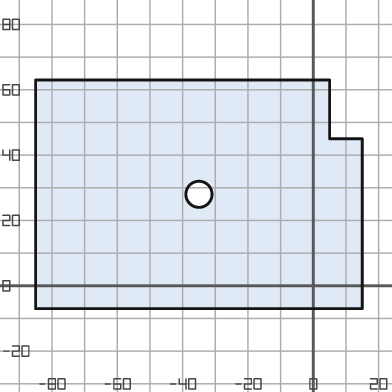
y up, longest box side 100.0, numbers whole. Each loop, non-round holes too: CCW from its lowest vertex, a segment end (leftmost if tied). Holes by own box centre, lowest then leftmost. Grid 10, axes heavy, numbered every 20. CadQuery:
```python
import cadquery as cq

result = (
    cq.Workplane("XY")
    .moveTo(-85.0, -7.0)
    .lineTo(15.0, -7.0)
    .lineTo(15.0, 45.0)
    .lineTo(5.0, 45.0)
    .lineTo(5.0, 63.0)
    .lineTo(-85.0, 63.0)
    .close()
    .moveTo(-35.0, 28.0)
    .circle(4.0)
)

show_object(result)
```